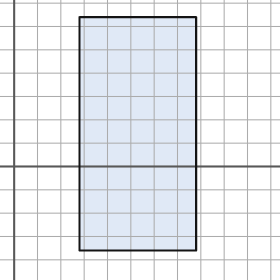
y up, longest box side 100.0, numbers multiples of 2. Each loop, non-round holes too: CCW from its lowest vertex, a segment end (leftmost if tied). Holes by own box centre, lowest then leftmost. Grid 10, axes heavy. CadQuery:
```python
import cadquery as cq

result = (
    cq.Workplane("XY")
    .moveTo(28.0, -36.0)
    .lineTo(78.0, -36.0)
    .lineTo(78.0, 64.0)
    .lineTo(28.0, 64.0)
    .close()
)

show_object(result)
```